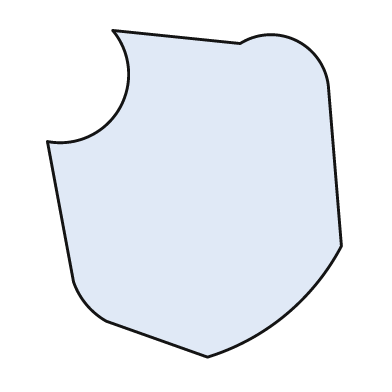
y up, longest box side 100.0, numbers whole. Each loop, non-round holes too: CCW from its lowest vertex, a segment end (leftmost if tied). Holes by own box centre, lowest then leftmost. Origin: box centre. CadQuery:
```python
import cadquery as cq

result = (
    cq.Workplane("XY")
    .moveTo(4.0, -50.0)
    .threePointArc((28.0, -37.0), (45.0, -16.0))
    .lineTo(41.0, 33.0)
    .threePointArc((31.0, 47.0), (14.0, 46.0))
    .lineTo(-25.0, 50.0)
    .threePointArc((-23.0, 26.0), (-45.0, 16.0))
    .lineTo(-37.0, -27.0)
    .threePointArc((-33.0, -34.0), (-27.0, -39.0))
    .close()
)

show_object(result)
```